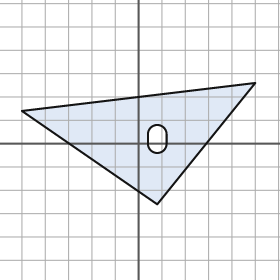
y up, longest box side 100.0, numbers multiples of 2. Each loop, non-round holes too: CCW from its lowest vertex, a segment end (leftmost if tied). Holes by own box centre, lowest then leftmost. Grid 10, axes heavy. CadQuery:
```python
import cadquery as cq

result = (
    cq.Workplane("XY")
    .moveTo(8.0, -26.0)
    .lineTo(50.0, 26.0)
    .lineTo(-50.0, 14.0)
    .close()
    .moveTo(4.0, 0.0)
    .threePointArc((8.0, -4.0), (12.0, 0.0))
    .lineTo(12.0, 4.0)
    .threePointArc((8.0, 8.0), (4.0, 4.0))
    .close()
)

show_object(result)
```